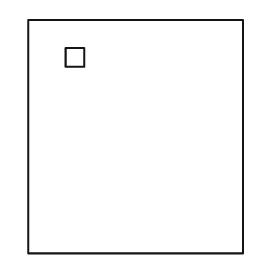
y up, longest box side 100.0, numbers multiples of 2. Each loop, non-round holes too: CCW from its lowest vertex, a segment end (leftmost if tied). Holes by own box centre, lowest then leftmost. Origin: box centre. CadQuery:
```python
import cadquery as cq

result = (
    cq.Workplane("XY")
    .moveTo(-46.0, -50.0)
    .lineTo(46.0, -50.0)
    .lineTo(46.0, 50.0)
    .lineTo(-46.0, 50.0)
    .close()
    .moveTo(-30.0, 30.0)
    .lineTo(-22.0, 30.0)
    .lineTo(-22.0, 38.0)
    .lineTo(-30.0, 38.0)
    .close()
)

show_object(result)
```